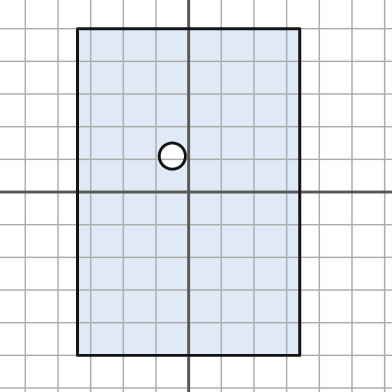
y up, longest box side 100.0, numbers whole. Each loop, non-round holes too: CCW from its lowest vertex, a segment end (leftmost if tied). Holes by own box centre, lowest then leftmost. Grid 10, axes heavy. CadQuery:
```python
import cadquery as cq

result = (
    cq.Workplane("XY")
    .moveTo(-34.0, -50.0)
    .lineTo(34.0, -50.0)
    .lineTo(34.0, 50.0)
    .lineTo(-34.0, 50.0)
    .close()
    .moveTo(-5.0, 11.0)
    .circle(4.0)
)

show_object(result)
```